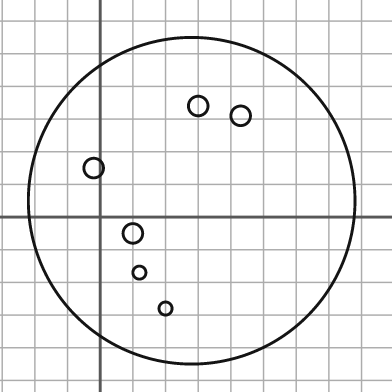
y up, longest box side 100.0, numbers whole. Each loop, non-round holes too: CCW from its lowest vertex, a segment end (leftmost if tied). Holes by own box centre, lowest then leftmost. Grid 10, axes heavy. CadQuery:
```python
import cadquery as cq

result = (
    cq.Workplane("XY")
    .moveTo(28.0, 5.0)
    .circle(50.0)
    .moveTo(20.0, -28.0)
    .circle(2.0)
    .moveTo(12.0, -17.0)
    .circle(2.0)
    .moveTo(10.0, -5.0)
    .circle(3.0)
    .moveTo(-2.0, 15.0)
    .circle(3.0)
    .moveTo(43.0, 31.0)
    .circle(3.0)
    .moveTo(30.0, 34.0)
    .circle(3.0)
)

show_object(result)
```